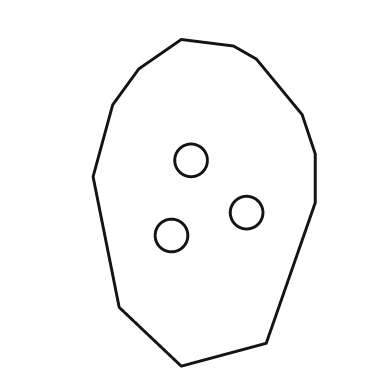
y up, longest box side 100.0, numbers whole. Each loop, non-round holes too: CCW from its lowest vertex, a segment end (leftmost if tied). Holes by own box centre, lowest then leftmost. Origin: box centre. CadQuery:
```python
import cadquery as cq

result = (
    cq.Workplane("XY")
    .moveTo(-7.0, -50.0)
    .lineTo(19.0, -43.0)
    .lineTo(34.0, 0.0)
    .lineTo(34.0, 15.0)
    .lineTo(30.0, 27.0)
    .lineTo(16.0, 44.0)
    .lineTo(9.0, 48.0)
    .lineTo(-7.0, 50.0)
    .lineTo(-20.0, 41.0)
    .lineTo(-28.0, 30.0)
    .lineTo(-34.0, 8.0)
    .lineTo(-26.0, -32.0)
    .close()
    .moveTo(-10.0, -10.0)
    .circle(5.0)
    .moveTo(13.0, -3.0)
    .circle(5.0)
    .moveTo(-4.0, 13.0)
    .circle(5.0)
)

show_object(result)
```